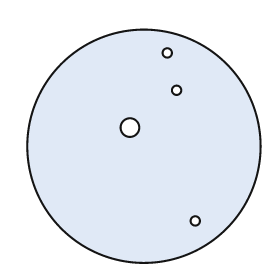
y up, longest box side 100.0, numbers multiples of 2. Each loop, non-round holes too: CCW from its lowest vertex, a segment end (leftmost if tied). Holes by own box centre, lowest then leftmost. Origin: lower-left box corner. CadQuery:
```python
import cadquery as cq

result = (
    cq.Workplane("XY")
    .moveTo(50.0, 50.0)
    .circle(50.0)
    .moveTo(72.0, 18.0)
    .circle(2.0)
    .moveTo(44.0, 58.0)
    .circle(4.0)
    .moveTo(64.0, 74.0)
    .circle(2.0)
    .moveTo(60.0, 90.0)
    .circle(2.0)
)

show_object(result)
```